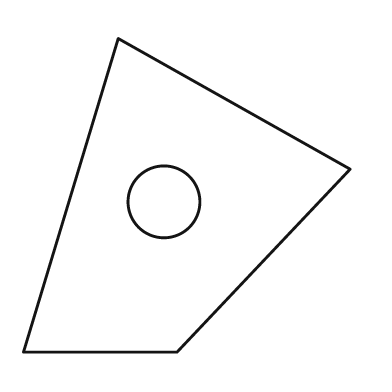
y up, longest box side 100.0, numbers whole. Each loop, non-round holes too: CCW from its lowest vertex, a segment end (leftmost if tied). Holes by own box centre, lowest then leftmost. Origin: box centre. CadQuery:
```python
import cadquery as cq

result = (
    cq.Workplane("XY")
    .moveTo(-50.0, -48.0)
    .lineTo(-3.0, -48.0)
    .lineTo(50.0, 8.0)
    .lineTo(-21.0, 48.0)
    .close()
    .moveTo(-7.0, -2.0)
    .circle(11.0)
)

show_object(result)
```